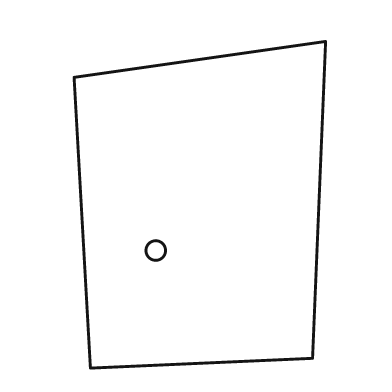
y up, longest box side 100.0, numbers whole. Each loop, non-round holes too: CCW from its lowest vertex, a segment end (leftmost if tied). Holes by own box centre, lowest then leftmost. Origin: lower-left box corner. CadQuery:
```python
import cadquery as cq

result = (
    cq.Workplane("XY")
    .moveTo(5.0, 0.0)
    .lineTo(73.0, 3.0)
    .lineTo(77.0, 100.0)
    .lineTo(0.0, 89.0)
    .close()
    .moveTo(25.0, 36.0)
    .circle(3.0)
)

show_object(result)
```